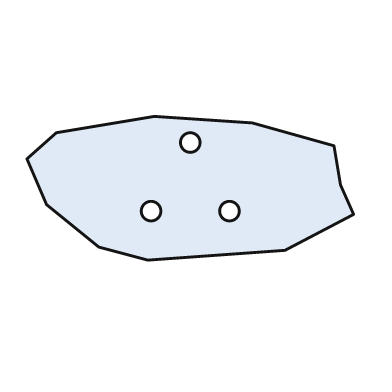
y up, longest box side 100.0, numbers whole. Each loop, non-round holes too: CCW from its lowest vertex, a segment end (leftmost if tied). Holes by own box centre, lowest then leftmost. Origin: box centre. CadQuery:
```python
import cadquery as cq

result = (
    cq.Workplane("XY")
    .moveTo(-13.0, -22.0)
    .lineTo(29.0, -19.0)
    .lineTo(50.0, -8.0)
    .lineTo(46.0, 1.0)
    .lineTo(44.0, 13.0)
    .lineTo(19.0, 20.0)
    .lineTo(-11.0, 22.0)
    .lineTo(-41.0, 17.0)
    .lineTo(-50.0, 9.0)
    .lineTo(-44.0, -5.0)
    .lineTo(-28.0, -18.0)
    .close()
    .moveTo(-12.0, -7.0)
    .circle(3.0)
    .moveTo(12.0, -7.0)
    .circle(3.0)
    .moveTo(0.0, 14.0)
    .circle(3.0)
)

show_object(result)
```